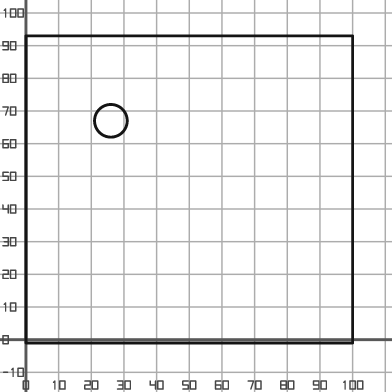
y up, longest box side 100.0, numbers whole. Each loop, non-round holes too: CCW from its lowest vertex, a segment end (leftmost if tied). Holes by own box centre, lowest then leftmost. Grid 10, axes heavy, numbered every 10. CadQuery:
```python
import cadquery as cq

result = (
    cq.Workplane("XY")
    .moveTo(0.0, -1.0)
    .lineTo(100.0, -1.0)
    .lineTo(100.0, 93.0)
    .lineTo(0.0, 93.0)
    .close()
    .moveTo(26.0, 67.0)
    .circle(5.0)
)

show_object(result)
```